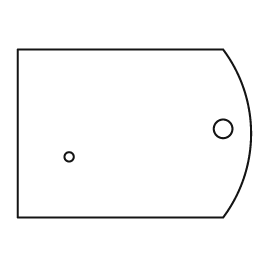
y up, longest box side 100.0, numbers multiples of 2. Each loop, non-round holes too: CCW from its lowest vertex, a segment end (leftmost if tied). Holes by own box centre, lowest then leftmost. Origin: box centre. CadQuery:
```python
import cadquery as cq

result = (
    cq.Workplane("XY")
    .moveTo(-50.0, -36.0)
    .lineTo(38.0, -36.0)
    .threePointArc((50.0, 0.0), (38.0, 36.0))
    .lineTo(-50.0, 36.0)
    .close()
    .moveTo(-28.0, -10.0)
    .circle(2.0)
    .moveTo(38.0, 2.0)
    .circle(4.0)
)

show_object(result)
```